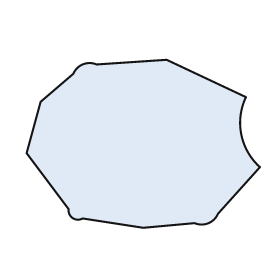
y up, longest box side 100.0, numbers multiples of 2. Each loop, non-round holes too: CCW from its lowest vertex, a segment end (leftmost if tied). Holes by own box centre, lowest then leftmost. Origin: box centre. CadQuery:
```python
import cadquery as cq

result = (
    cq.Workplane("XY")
    .moveTo(0.0, -36.0)
    .lineTo(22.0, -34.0)
    .threePointArc((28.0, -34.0), (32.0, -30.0))
    .lineTo(50.0, -10.0)
    .threePointArc((42.0, 4.0), (44.0, 20.0))
    .lineTo(10.0, 36.0)
    .lineTo(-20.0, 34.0)
    .threePointArc((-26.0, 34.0), (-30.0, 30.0))
    .lineTo(-44.0, 18.0)
    .lineTo(-50.0, -4.0)
    .lineTo(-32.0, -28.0)
    .threePointArc((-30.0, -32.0), (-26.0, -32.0))
    .close()
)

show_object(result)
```